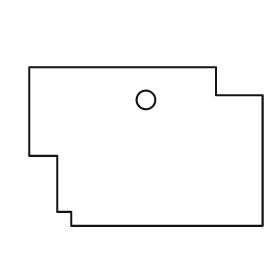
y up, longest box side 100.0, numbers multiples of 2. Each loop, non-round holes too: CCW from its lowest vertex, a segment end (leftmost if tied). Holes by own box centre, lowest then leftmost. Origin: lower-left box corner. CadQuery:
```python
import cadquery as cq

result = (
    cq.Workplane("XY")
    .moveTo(18.0, 0.0)
    .lineTo(100.0, 0.0)
    .lineTo(100.0, 56.0)
    .lineTo(80.0, 56.0)
    .lineTo(80.0, 68.0)
    .lineTo(0.0, 68.0)
    .lineTo(0.0, 30.0)
    .lineTo(12.0, 30.0)
    .lineTo(12.0, 6.0)
    .lineTo(18.0, 6.0)
    .close()
    .moveTo(50.0, 54.0)
    .circle(4.0)
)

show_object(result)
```